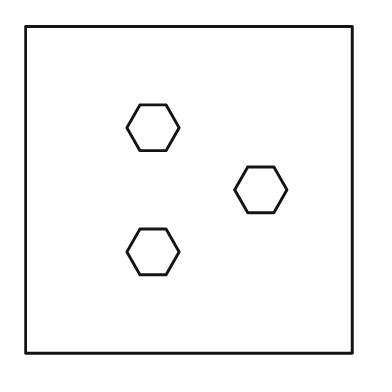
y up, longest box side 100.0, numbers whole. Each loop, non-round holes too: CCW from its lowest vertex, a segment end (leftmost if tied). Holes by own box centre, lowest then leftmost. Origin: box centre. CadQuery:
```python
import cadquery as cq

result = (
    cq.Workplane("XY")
    .moveTo(-50.0, -50.0)
    .lineTo(50.0, -50.0)
    .lineTo(50.0, 50.0)
    .lineTo(-50.0, 50.0)
    .close()
    .moveTo(-15.0, -26.0)
    .lineTo(-7.0, -26.0)
    .lineTo(-3.0, -19.0)
    .lineTo(-7.0, -12.0)
    .lineTo(-15.0, -12.0)
    .lineTo(-19.0, -19.0)
    .close()
    .moveTo(18.0, -7.0)
    .lineTo(26.0, -7.0)
    .lineTo(30.0, 0.0)
    .lineTo(26.0, 7.0)
    .lineTo(18.0, 7.0)
    .lineTo(14.0, 0.0)
    .close()
    .moveTo(-15.0, 12.0)
    .lineTo(-7.0, 12.0)
    .lineTo(-3.0, 19.0)
    .lineTo(-7.0, 26.0)
    .lineTo(-15.0, 26.0)
    .lineTo(-19.0, 19.0)
    .close()
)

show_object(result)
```